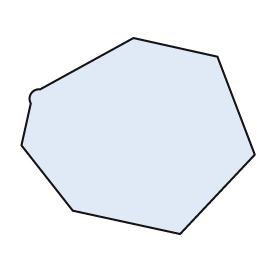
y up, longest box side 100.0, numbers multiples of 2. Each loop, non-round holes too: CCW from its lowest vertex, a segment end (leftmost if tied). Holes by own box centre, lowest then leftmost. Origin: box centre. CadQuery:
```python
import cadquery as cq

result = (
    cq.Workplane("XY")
    .moveTo(18.0, -42.0)
    .lineTo(50.0, -8.0)
    .lineTo(34.0, 34.0)
    .lineTo(-2.0, 42.0)
    .lineTo(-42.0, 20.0)
    .threePointArc((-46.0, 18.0), (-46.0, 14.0))
    .lineTo(-50.0, -4.0)
    .lineTo(-28.0, -32.0)
    .close()
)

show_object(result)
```